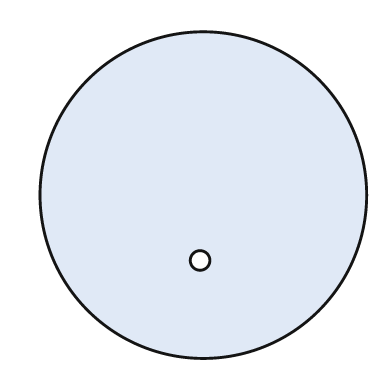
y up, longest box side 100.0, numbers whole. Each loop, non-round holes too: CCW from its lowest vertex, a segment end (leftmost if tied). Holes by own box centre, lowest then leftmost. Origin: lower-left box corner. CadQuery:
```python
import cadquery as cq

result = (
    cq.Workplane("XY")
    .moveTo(50.0, 50.0)
    .circle(50.0)
    .moveTo(49.0, 30.0)
    .circle(3.0)
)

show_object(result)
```